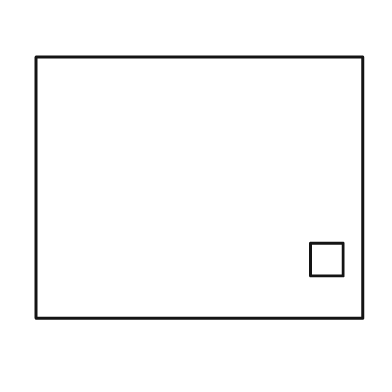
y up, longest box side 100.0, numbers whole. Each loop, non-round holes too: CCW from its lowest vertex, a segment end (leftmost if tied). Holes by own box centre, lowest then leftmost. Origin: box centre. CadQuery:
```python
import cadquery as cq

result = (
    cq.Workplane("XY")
    .moveTo(-50.0, -40.0)
    .lineTo(50.0, -40.0)
    .lineTo(50.0, 40.0)
    .lineTo(-50.0, 40.0)
    .close()
    .moveTo(34.0, -27.0)
    .lineTo(44.0, -27.0)
    .lineTo(44.0, -17.0)
    .lineTo(34.0, -17.0)
    .close()
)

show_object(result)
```